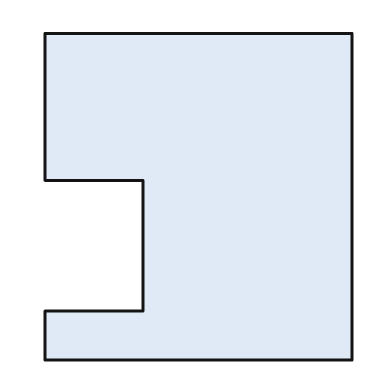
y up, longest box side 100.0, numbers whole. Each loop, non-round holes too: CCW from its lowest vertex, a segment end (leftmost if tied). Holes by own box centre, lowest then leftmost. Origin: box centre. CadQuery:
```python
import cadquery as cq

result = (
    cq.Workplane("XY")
    .moveTo(-47.0, -50.0)
    .lineTo(47.0, -50.0)
    .lineTo(47.0, 50.0)
    .lineTo(-47.0, 50.0)
    .lineTo(-47.0, 5.0)
    .lineTo(-17.0, 5.0)
    .lineTo(-17.0, -35.0)
    .lineTo(-47.0, -35.0)
    .close()
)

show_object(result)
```